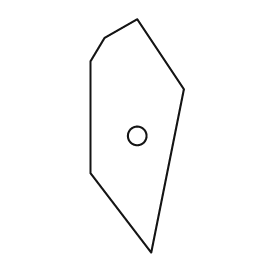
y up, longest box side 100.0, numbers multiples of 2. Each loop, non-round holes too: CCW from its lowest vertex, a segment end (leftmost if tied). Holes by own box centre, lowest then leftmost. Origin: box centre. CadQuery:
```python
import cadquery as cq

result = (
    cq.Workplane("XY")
    .moveTo(6.0, -50.0)
    .lineTo(20.0, 20.0)
    .lineTo(0.0, 50.0)
    .lineTo(-14.0, 42.0)
    .lineTo(-20.0, 32.0)
    .lineTo(-20.0, -16.0)
    .close()
    .moveTo(0.0, 0.0)
    .circle(4.0)
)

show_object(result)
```